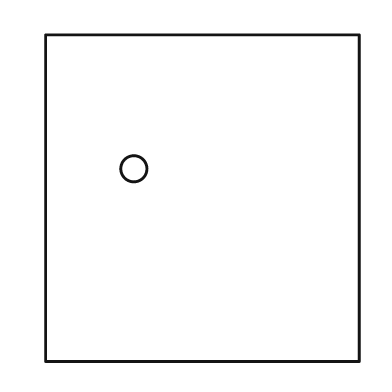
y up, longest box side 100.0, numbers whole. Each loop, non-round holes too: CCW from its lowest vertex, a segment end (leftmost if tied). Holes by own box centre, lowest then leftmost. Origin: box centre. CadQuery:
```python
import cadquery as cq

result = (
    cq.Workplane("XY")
    .moveTo(-48.0, -50.0)
    .lineTo(48.0, -50.0)
    .lineTo(48.0, 50.0)
    .lineTo(-48.0, 50.0)
    .close()
    .moveTo(-21.0, 9.0)
    .circle(4.0)
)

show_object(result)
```